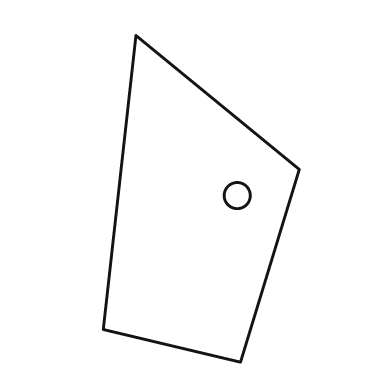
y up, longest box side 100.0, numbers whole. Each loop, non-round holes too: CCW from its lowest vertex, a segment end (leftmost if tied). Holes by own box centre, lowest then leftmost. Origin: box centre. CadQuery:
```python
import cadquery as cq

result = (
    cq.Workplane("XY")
    .moveTo(12.0, -50.0)
    .lineTo(30.0, 9.0)
    .lineTo(-20.0, 50.0)
    .lineTo(-30.0, -40.0)
    .close()
    .moveTo(11.0, 1.0)
    .circle(4.0)
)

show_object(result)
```